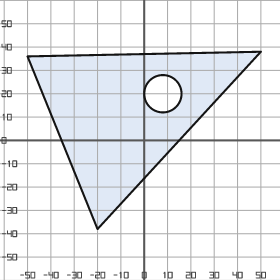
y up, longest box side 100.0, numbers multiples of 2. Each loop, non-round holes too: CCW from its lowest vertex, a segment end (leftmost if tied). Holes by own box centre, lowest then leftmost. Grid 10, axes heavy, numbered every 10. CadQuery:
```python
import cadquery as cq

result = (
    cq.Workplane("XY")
    .moveTo(-20.0, -38.0)
    .lineTo(50.0, 38.0)
    .lineTo(-50.0, 36.0)
    .close()
    .moveTo(8.0, 20.0)
    .circle(8.0)
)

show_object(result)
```